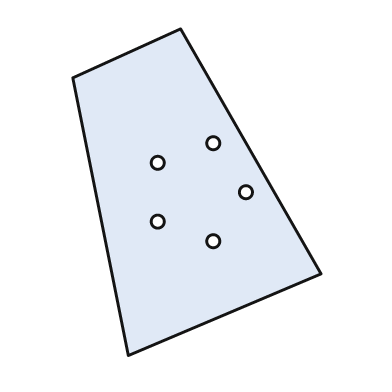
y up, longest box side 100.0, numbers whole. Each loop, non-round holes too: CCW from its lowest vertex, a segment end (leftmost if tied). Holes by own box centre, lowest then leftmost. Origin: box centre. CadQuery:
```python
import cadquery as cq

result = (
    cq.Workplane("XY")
    .moveTo(-21.0, -50.0)
    .lineTo(38.0, -25.0)
    .lineTo(-5.0, 50.0)
    .lineTo(-38.0, 35.0)
    .close()
    .moveTo(5.0, -15.0)
    .circle(2.0)
    .moveTo(-12.0, -9.0)
    .circle(2.0)
    .moveTo(15.0, 0.0)
    .circle(2.0)
    .moveTo(-12.0, 9.0)
    .circle(2.0)
    .moveTo(5.0, 15.0)
    .circle(2.0)
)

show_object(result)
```